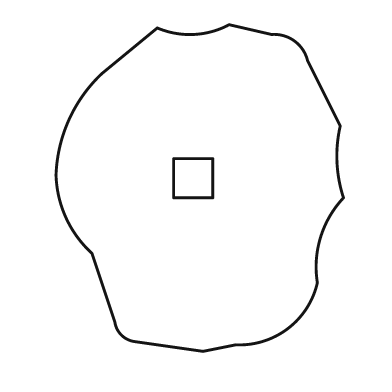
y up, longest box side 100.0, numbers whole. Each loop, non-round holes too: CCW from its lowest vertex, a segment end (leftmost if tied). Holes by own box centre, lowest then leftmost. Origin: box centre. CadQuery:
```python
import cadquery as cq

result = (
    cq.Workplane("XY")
    .moveTo(1.0, -50.0)
    .lineTo(11.0, -48.0)
    .threePointArc((27.0, -43.0), (36.0, -29.0))
    .threePointArc((37.0, -15.0), (44.0, -3.0))
    .threePointArc((42.0, 8.0), (43.0, 19.0))
    .lineTo(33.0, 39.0)
    .threePointArc((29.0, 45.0), (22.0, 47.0))
    .lineTo(9.0, 50.0)
    .threePointArc((-2.0, 47.0), (-13.0, 49.0))
    .lineTo(-30.0, 35.0)
    .threePointArc((-40.0, 21.0), (-44.0, 4.0))
    .threePointArc((-41.0, -9.0), (-33.0, -20.0))
    .lineTo(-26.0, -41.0)
    .threePointArc((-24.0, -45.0), (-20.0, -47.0))
    .close()
    .moveTo(-8.0, -3.0)
    .lineTo(4.0, -3.0)
    .lineTo(4.0, 9.0)
    .lineTo(-8.0, 9.0)
    .close()
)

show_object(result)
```